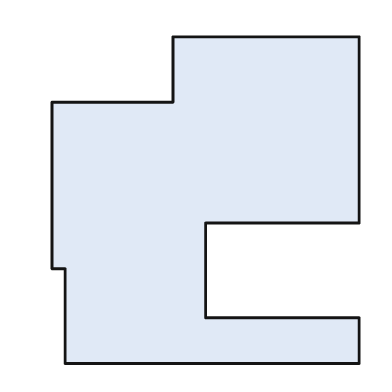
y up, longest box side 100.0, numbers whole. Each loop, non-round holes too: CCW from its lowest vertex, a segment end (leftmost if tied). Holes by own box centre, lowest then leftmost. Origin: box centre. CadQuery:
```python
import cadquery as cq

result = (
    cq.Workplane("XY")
    .moveTo(-43.0, -50.0)
    .lineTo(47.0, -50.0)
    .lineTo(47.0, -36.0)
    .lineTo(0.0, -36.0)
    .lineTo(0.0, -7.0)
    .lineTo(47.0, -7.0)
    .lineTo(47.0, 50.0)
    .lineTo(-10.0, 50.0)
    .lineTo(-10.0, 30.0)
    .lineTo(-47.0, 30.0)
    .lineTo(-47.0, -21.0)
    .lineTo(-43.0, -21.0)
    .close()
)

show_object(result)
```